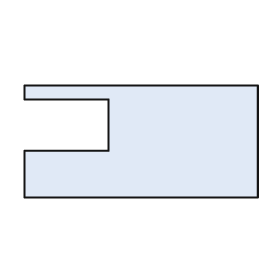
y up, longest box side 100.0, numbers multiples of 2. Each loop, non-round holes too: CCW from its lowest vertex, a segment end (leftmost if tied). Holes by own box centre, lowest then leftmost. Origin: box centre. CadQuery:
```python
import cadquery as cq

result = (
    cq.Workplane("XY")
    .moveTo(-50.0, -24.0)
    .lineTo(50.0, -24.0)
    .lineTo(50.0, 24.0)
    .lineTo(-50.0, 24.0)
    .lineTo(-50.0, 18.0)
    .lineTo(-14.0, 18.0)
    .lineTo(-14.0, -4.0)
    .lineTo(-50.0, -4.0)
    .close()
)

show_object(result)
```